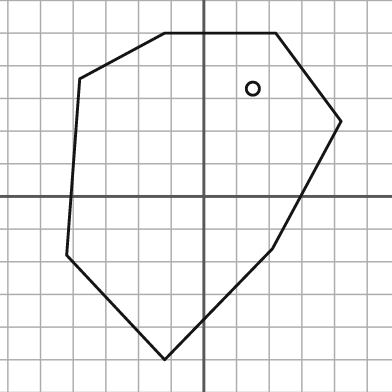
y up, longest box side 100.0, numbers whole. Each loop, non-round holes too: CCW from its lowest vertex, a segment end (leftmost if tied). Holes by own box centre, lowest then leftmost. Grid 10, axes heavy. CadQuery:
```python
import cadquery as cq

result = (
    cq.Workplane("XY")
    .moveTo(-12.0, -50.0)
    .lineTo(21.0, -16.0)
    .lineTo(42.0, 23.0)
    .lineTo(22.0, 50.0)
    .lineTo(-12.0, 50.0)
    .lineTo(-38.0, 36.0)
    .lineTo(-42.0, -18.0)
    .close()
    .moveTo(15.0, 33.0)
    .circle(2.0)
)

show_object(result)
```